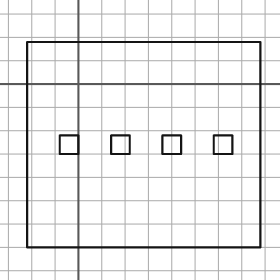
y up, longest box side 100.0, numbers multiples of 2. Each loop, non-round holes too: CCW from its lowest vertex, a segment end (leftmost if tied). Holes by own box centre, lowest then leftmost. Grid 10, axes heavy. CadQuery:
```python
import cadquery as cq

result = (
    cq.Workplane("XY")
    .moveTo(-22.0, -70.0)
    .lineTo(78.0, -70.0)
    .lineTo(78.0, 18.0)
    .lineTo(-22.0, 18.0)
    .close()
    .moveTo(-8.0, -30.0)
    .lineTo(0.0, -30.0)
    .lineTo(0.0, -22.0)
    .lineTo(-8.0, -22.0)
    .close()
    .moveTo(14.0, -30.0)
    .lineTo(22.0, -30.0)
    .lineTo(22.0, -22.0)
    .lineTo(14.0, -22.0)
    .close()
    .moveTo(36.0, -30.0)
    .lineTo(44.0, -30.0)
    .lineTo(44.0, -22.0)
    .lineTo(36.0, -22.0)
    .close()
    .moveTo(58.0, -30.0)
    .lineTo(66.0, -30.0)
    .lineTo(66.0, -22.0)
    .lineTo(58.0, -22.0)
    .close()
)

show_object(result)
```